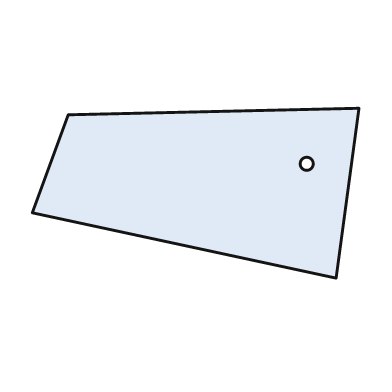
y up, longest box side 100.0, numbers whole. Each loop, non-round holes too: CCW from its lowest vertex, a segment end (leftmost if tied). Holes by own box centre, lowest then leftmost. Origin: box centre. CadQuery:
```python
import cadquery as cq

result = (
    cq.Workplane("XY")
    .moveTo(43.0, -26.0)
    .lineTo(50.0, 26.0)
    .lineTo(-39.0, 24.0)
    .lineTo(-50.0, -6.0)
    .close()
    .moveTo(34.0, 9.0)
    .circle(2.0)
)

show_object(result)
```